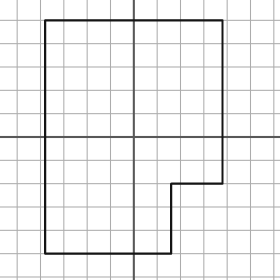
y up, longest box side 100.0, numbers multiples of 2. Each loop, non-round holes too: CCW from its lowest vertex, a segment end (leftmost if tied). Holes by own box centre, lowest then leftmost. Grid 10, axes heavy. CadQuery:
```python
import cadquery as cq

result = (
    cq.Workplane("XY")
    .moveTo(-38.0, -50.0)
    .lineTo(16.0, -50.0)
    .lineTo(16.0, -20.0)
    .lineTo(38.0, -20.0)
    .lineTo(38.0, 50.0)
    .lineTo(-38.0, 50.0)
    .close()
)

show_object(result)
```